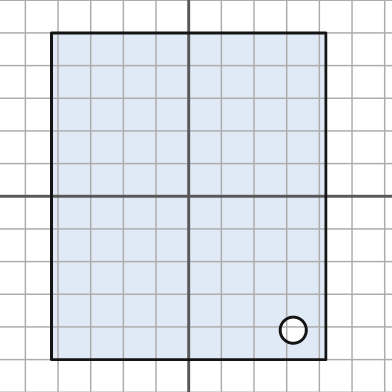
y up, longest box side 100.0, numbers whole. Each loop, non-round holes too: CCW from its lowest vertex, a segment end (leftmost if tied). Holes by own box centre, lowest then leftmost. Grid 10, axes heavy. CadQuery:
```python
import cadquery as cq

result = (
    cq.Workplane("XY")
    .moveTo(-42.0, -50.0)
    .lineTo(42.0, -50.0)
    .lineTo(42.0, 50.0)
    .lineTo(-42.0, 50.0)
    .close()
    .moveTo(32.0, -41.0)
    .circle(4.0)
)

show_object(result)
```